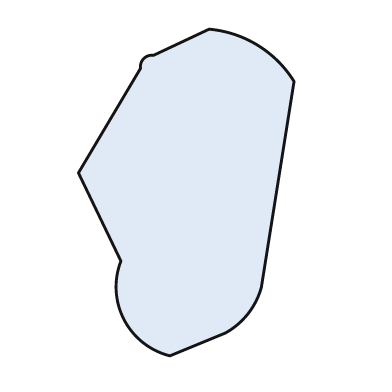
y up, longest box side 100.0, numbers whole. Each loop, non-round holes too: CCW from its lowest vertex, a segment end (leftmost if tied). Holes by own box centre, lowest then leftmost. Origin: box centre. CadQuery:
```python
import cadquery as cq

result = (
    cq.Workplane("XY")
    .moveTo(-5.0, -50.0)
    .lineTo(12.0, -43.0)
    .threePointArc((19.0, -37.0), (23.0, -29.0))
    .lineTo(33.0, 34.0)
    .threePointArc((22.0, 45.0), (7.0, 50.0))
    .lineTo(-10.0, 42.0)
    .threePointArc((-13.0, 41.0), (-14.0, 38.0))
    .lineTo(-33.0, 6.0)
    .lineTo(-20.0, -21.0)
    .threePointArc((-19.0, -39.0), (-5.0, -50.0))
    .close()
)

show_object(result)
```